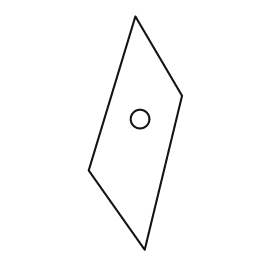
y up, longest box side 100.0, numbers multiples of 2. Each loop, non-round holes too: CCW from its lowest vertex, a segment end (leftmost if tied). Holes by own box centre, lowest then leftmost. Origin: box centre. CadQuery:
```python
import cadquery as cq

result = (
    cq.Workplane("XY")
    .moveTo(4.0, -50.0)
    .lineTo(20.0, 16.0)
    .lineTo(0.0, 50.0)
    .lineTo(-20.0, -16.0)
    .close()
    .moveTo(2.0, 6.0)
    .circle(4.0)
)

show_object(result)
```